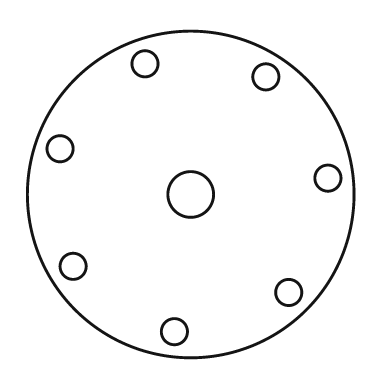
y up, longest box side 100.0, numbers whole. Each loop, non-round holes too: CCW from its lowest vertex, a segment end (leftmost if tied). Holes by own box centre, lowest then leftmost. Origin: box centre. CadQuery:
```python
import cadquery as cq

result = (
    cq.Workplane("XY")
    .moveTo(0.0, 0.0)
    .circle(50.0)
    .moveTo(-5.0, -42.0)
    .circle(4.0)
    .moveTo(30.0, -30.0)
    .circle(4.0)
    .moveTo(-36.0, -22.0)
    .circle(4.0)
    .moveTo(0.0, 0.0)
    .circle(7.0)
    .moveTo(42.0, 5.0)
    .circle(4.0)
    .moveTo(-40.0, 14.0)
    .circle(4.0)
    .moveTo(23.0, 36.0)
    .circle(4.0)
    .moveTo(-14.0, 40.0)
    .circle(4.0)
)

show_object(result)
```